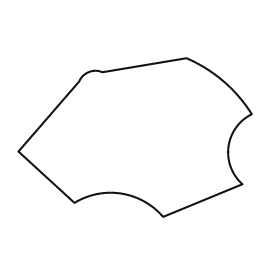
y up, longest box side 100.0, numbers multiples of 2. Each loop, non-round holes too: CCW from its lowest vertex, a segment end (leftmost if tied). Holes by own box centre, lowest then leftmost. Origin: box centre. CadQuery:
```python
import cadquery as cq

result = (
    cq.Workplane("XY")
    .moveTo(12.0, -34.0)
    .lineTo(46.0, -20.0)
    .threePointArc((40.0, -4.0), (50.0, 10.0))
    .threePointArc((38.0, 24.0), (22.0, 34.0))
    .lineTo(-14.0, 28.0)
    .threePointArc((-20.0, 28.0), (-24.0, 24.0))
    .lineTo(-50.0, -6.0)
    .lineTo(-26.0, -28.0)
    .threePointArc((-6.0, -24.0), (12.0, -34.0))
    .close()
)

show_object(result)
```